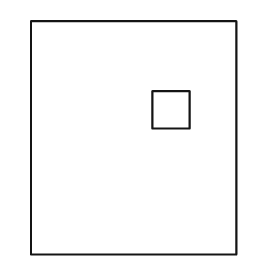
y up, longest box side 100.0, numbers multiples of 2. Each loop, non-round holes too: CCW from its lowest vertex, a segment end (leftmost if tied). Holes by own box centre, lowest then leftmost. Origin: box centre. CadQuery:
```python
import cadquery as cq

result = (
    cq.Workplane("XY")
    .moveTo(-44.0, -50.0)
    .lineTo(44.0, -50.0)
    .lineTo(44.0, 50.0)
    .lineTo(-44.0, 50.0)
    .close()
    .moveTo(8.0, 4.0)
    .lineTo(24.0, 4.0)
    .lineTo(24.0, 20.0)
    .lineTo(8.0, 20.0)
    .close()
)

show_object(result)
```